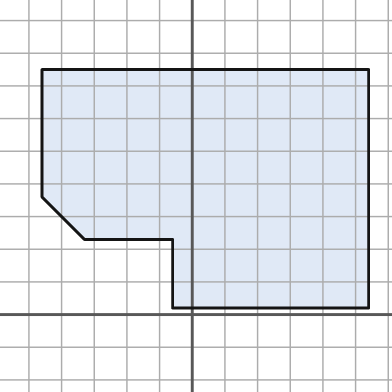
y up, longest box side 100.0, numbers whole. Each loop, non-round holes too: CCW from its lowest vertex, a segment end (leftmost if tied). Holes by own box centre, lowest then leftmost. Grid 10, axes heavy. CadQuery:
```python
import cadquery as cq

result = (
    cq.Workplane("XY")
    .moveTo(-6.0, 2.0)
    .lineTo(54.0, 2.0)
    .lineTo(54.0, 75.0)
    .lineTo(-46.0, 75.0)
    .lineTo(-46.0, 36.0)
    .lineTo(-33.0, 23.0)
    .lineTo(-6.0, 23.0)
    .close()
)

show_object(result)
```